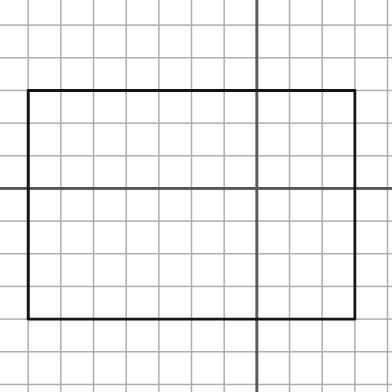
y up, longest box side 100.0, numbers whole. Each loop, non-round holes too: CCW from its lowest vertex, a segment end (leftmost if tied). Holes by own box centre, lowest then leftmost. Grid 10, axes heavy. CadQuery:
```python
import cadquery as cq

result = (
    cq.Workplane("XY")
    .moveTo(-70.0, -40.0)
    .lineTo(30.0, -40.0)
    .lineTo(30.0, 30.0)
    .lineTo(-70.0, 30.0)
    .close()
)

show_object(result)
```